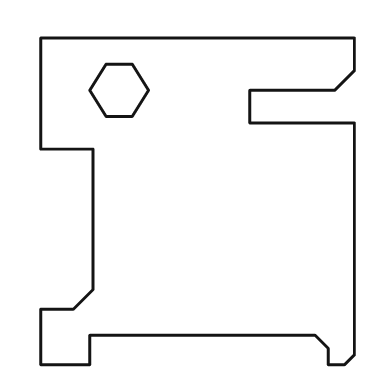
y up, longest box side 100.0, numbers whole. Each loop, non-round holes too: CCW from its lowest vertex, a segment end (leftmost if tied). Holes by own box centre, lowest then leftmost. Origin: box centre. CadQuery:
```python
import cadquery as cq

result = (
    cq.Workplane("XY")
    .moveTo(-48.0, -50.0)
    .lineTo(-33.0, -50.0)
    .lineTo(-33.0, -41.0)
    .lineTo(36.0, -41.0)
    .lineTo(40.0, -45.0)
    .lineTo(40.0, -50.0)
    .lineTo(45.0, -50.0)
    .lineTo(48.0, -47.0)
    .lineTo(48.0, 24.0)
    .lineTo(16.0, 24.0)
    .lineTo(16.0, 34.0)
    .lineTo(42.0, 34.0)
    .lineTo(48.0, 40.0)
    .lineTo(48.0, 50.0)
    .lineTo(-48.0, 50.0)
    .lineTo(-48.0, 16.0)
    .lineTo(-32.0, 16.0)
    .lineTo(-32.0, -27.0)
    .lineTo(-38.0, -33.0)
    .lineTo(-48.0, -33.0)
    .close()
    .moveTo(-28.0, 26.0)
    .lineTo(-20.0, 26.0)
    .lineTo(-15.0, 34.0)
    .lineTo(-20.0, 42.0)
    .lineTo(-28.0, 42.0)
    .lineTo(-33.0, 34.0)
    .close()
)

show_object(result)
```